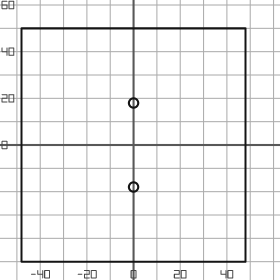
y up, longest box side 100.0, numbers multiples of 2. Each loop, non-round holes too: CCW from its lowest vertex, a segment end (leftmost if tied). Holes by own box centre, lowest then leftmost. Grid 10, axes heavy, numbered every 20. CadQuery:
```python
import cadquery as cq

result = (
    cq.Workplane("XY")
    .moveTo(-48.0, -50.0)
    .lineTo(48.0, -50.0)
    .lineTo(48.0, 50.0)
    .lineTo(-48.0, 50.0)
    .close()
    .moveTo(0.0, -18.0)
    .circle(2.0)
    .moveTo(0.0, 18.0)
    .circle(2.0)
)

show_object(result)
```